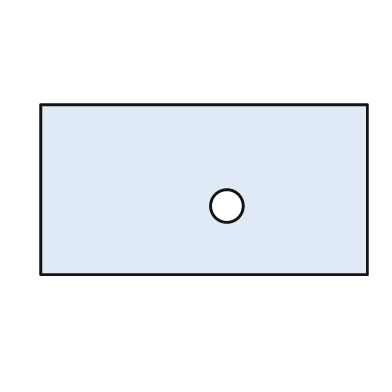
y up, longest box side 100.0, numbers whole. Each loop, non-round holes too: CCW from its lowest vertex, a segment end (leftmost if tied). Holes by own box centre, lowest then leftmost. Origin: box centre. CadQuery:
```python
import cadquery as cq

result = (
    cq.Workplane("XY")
    .moveTo(-50.0, -26.0)
    .lineTo(50.0, -26.0)
    .lineTo(50.0, 26.0)
    .lineTo(-50.0, 26.0)
    .close()
    .moveTo(7.0, -5.0)
    .circle(5.0)
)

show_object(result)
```